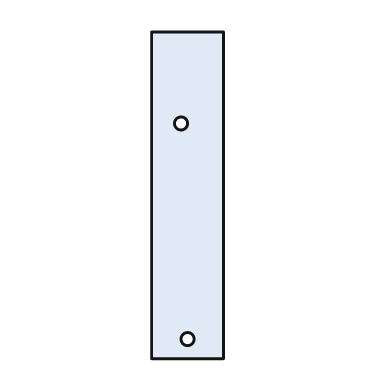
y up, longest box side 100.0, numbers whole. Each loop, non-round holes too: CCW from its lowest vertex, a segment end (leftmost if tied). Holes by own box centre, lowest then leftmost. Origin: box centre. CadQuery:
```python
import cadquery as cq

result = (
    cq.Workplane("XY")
    .moveTo(-11.0, -50.0)
    .lineTo(11.0, -50.0)
    .lineTo(11.0, 50.0)
    .lineTo(-11.0, 50.0)
    .close()
    .moveTo(0.0, -44.0)
    .circle(2.0)
    .moveTo(-2.0, 22.0)
    .circle(2.0)
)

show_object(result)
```